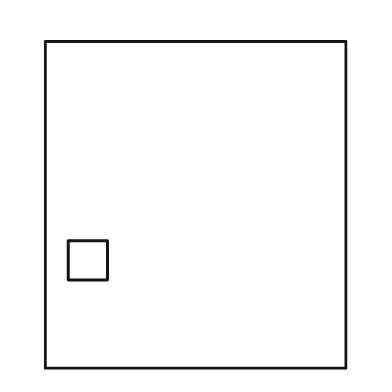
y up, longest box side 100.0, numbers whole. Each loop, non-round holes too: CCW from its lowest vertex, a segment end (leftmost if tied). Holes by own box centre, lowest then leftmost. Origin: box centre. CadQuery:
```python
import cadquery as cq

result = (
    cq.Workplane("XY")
    .moveTo(-46.0, -50.0)
    .lineTo(46.0, -50.0)
    .lineTo(46.0, 50.0)
    .lineTo(-46.0, 50.0)
    .close()
    .moveTo(-39.0, -23.0)
    .lineTo(-27.0, -23.0)
    .lineTo(-27.0, -11.0)
    .lineTo(-39.0, -11.0)
    .close()
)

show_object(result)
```